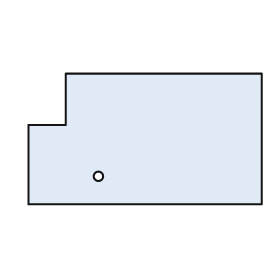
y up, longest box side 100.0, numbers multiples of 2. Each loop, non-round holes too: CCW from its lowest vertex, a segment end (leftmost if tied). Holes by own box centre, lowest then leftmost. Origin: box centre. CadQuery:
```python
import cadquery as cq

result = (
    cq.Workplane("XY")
    .moveTo(-50.0, -28.0)
    .lineTo(50.0, -28.0)
    .lineTo(50.0, 28.0)
    .lineTo(-34.0, 28.0)
    .lineTo(-34.0, 6.0)
    .lineTo(-50.0, 6.0)
    .close()
    .moveTo(-20.0, -16.0)
    .circle(2.0)
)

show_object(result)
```